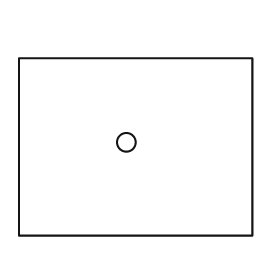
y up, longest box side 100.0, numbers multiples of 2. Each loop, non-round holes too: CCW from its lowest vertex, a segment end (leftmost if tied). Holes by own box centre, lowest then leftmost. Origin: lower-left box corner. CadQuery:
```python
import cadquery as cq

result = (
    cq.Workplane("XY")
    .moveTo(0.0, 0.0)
    .lineTo(100.0, 0.0)
    .lineTo(100.0, 76.0)
    .lineTo(0.0, 76.0)
    .close()
    .moveTo(46.0, 40.0)
    .circle(4.0)
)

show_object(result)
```